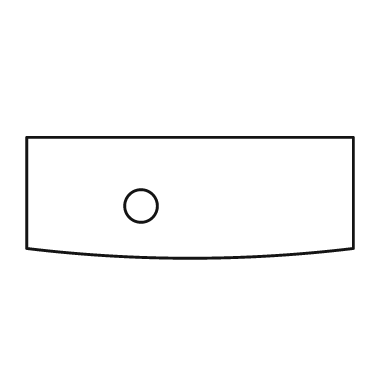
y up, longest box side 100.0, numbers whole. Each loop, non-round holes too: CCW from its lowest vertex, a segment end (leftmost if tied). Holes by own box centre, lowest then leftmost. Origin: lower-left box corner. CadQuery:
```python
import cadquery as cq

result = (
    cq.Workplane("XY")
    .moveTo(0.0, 3.0)
    .threePointArc((50.0, 0.0), (100.0, 3.0))
    .lineTo(100.0, 37.0)
    .lineTo(0.0, 37.0)
    .close()
    .moveTo(35.0, 16.0)
    .circle(5.0)
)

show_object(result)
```